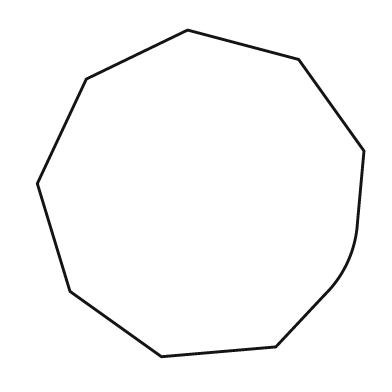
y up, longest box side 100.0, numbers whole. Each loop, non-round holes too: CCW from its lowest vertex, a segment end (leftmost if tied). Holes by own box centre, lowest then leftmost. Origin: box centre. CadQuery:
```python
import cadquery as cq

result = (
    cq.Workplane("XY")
    .moveTo(-12.0, -50.0)
    .lineTo(23.0, -47.0)
    .lineTo(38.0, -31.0)
    .threePointArc((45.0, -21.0), (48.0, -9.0))
    .lineTo(50.0, 13.0)
    .lineTo(30.0, 41.0)
    .lineTo(-4.0, 50.0)
    .lineTo(-35.0, 35.0)
    .lineTo(-50.0, 3.0)
    .lineTo(-40.0, -30.0)
    .close()
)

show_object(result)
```